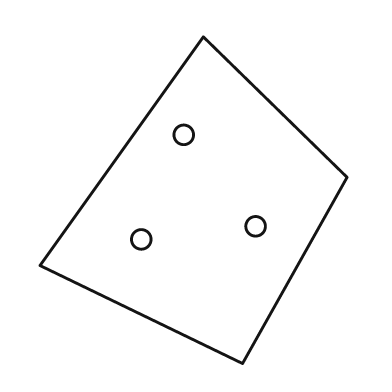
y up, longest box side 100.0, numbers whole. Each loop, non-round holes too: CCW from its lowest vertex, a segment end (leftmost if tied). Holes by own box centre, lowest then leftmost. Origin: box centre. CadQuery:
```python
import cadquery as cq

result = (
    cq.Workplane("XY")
    .moveTo(15.0, -50.0)
    .lineTo(47.0, 7.0)
    .lineTo(3.0, 50.0)
    .lineTo(-47.0, -20.0)
    .close()
    .moveTo(-16.0, -12.0)
    .circle(3.0)
    .moveTo(19.0, -8.0)
    .circle(3.0)
    .moveTo(-3.0, 20.0)
    .circle(3.0)
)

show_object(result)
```